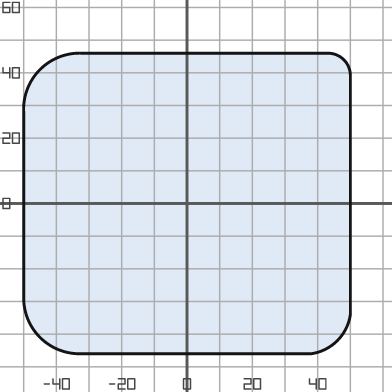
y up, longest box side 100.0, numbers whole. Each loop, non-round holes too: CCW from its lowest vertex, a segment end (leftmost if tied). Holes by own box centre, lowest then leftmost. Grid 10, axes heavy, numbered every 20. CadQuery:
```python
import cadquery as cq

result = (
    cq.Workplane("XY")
    .moveTo(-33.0, -46.0)
    .lineTo(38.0, -46.0)
    .threePointArc((46.0, -42.0), (50.0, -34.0))
    .lineTo(50.0, 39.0)
    .threePointArc((48.0, 44.0), (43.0, 46.0))
    .lineTo(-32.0, 46.0)
    .threePointArc((-45.0, 41.0), (-50.0, 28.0))
    .lineTo(-50.0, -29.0)
    .threePointArc((-45.0, -41.0), (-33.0, -46.0))
    .close()
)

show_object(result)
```